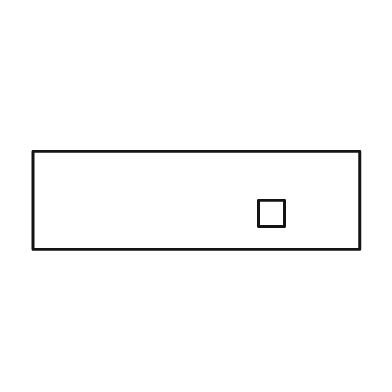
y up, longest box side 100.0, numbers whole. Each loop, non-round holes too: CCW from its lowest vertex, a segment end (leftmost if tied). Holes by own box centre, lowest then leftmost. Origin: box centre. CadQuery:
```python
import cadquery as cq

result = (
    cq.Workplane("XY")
    .moveTo(-50.0, -15.0)
    .lineTo(50.0, -15.0)
    .lineTo(50.0, 15.0)
    .lineTo(-50.0, 15.0)
    .close()
    .moveTo(19.0, -8.0)
    .lineTo(27.0, -8.0)
    .lineTo(27.0, 0.0)
    .lineTo(19.0, 0.0)
    .close()
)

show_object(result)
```